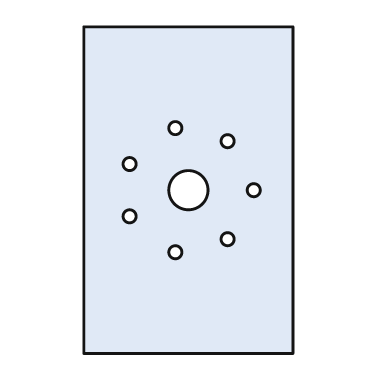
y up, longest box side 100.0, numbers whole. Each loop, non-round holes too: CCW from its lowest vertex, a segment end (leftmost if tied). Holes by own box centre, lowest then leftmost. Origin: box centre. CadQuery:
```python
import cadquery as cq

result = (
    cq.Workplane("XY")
    .moveTo(-32.0, -50.0)
    .lineTo(32.0, -50.0)
    .lineTo(32.0, 50.0)
    .lineTo(-32.0, 50.0)
    .close()
    .moveTo(-4.0, -19.0)
    .circle(2.0)
    .moveTo(12.0, -15.0)
    .circle(2.0)
    .moveTo(-18.0, -8.0)
    .circle(2.0)
    .moveTo(0.0, 0.0)
    .circle(6.0)
    .moveTo(20.0, 0.0)
    .circle(2.0)
    .moveTo(-18.0, 8.0)
    .circle(2.0)
    .moveTo(12.0, 15.0)
    .circle(2.0)
    .moveTo(-4.0, 19.0)
    .circle(2.0)
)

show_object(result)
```